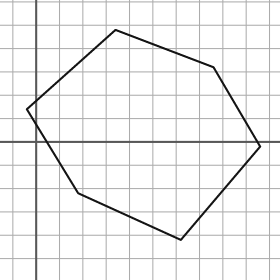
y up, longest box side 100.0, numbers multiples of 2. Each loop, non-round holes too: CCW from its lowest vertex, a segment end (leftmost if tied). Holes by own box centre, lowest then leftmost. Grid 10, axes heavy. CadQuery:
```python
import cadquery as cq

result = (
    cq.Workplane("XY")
    .moveTo(62.0, -42.0)
    .lineTo(96.0, -2.0)
    .lineTo(76.0, 32.0)
    .lineTo(34.0, 48.0)
    .lineTo(-4.0, 14.0)
    .lineTo(18.0, -22.0)
    .close()
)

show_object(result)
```